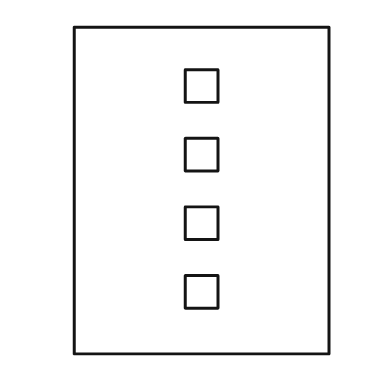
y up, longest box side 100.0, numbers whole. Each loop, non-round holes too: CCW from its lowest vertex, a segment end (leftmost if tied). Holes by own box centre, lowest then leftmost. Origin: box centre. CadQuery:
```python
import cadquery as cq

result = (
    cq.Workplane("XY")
    .moveTo(-39.0, -50.0)
    .lineTo(39.0, -50.0)
    .lineTo(39.0, 50.0)
    .lineTo(-39.0, 50.0)
    .close()
    .moveTo(-5.0, -36.0)
    .lineTo(5.0, -36.0)
    .lineTo(5.0, -26.0)
    .lineTo(-5.0, -26.0)
    .close()
    .moveTo(-5.0, -15.0)
    .lineTo(5.0, -15.0)
    .lineTo(5.0, -5.0)
    .lineTo(-5.0, -5.0)
    .close()
    .moveTo(-5.0, 6.0)
    .lineTo(5.0, 6.0)
    .lineTo(5.0, 16.0)
    .lineTo(-5.0, 16.0)
    .close()
    .moveTo(-5.0, 27.0)
    .lineTo(5.0, 27.0)
    .lineTo(5.0, 37.0)
    .lineTo(-5.0, 37.0)
    .close()
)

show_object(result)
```